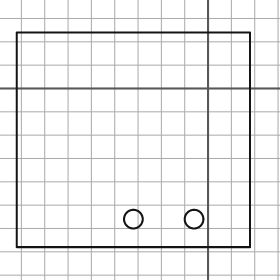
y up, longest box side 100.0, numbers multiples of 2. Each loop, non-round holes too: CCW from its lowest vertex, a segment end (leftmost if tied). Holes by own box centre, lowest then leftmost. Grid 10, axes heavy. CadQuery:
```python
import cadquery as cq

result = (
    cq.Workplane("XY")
    .moveTo(-82.0, -68.0)
    .lineTo(18.0, -68.0)
    .lineTo(18.0, 24.0)
    .lineTo(-82.0, 24.0)
    .close()
    .moveTo(-32.0, -56.0)
    .circle(4.0)
    .moveTo(-6.0, -56.0)
    .circle(4.0)
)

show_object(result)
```